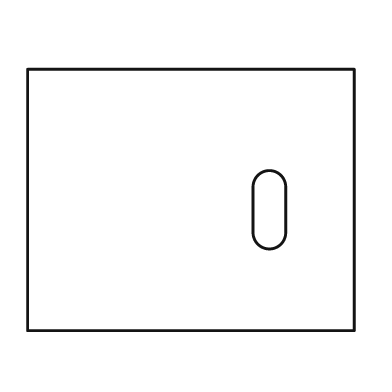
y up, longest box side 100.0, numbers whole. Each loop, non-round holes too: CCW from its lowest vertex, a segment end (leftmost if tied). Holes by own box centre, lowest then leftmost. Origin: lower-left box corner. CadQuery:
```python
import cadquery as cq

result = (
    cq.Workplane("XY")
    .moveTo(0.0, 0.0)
    .lineTo(100.0, 0.0)
    .lineTo(100.0, 80.0)
    .lineTo(0.0, 80.0)
    .close()
    .moveTo(69.0, 30.0)
    .threePointArc((74.0, 25.0), (79.0, 30.0))
    .lineTo(79.0, 44.0)
    .threePointArc((74.0, 49.0), (69.0, 44.0))
    .close()
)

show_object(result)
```